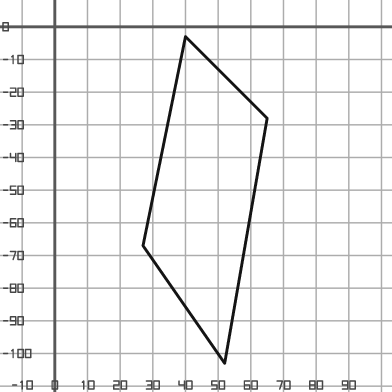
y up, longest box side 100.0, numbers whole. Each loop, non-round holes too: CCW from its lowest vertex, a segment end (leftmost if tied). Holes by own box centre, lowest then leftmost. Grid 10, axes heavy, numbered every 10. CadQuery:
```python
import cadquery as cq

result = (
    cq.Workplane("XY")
    .moveTo(52.0, -103.0)
    .lineTo(65.0, -28.0)
    .lineTo(40.0, -3.0)
    .lineTo(27.0, -67.0)
    .close()
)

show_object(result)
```